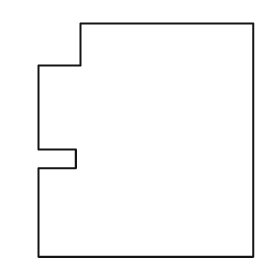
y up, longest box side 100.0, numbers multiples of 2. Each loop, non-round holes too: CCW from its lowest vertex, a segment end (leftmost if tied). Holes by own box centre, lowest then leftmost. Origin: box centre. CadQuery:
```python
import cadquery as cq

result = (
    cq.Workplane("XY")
    .moveTo(-46.0, -50.0)
    .lineTo(46.0, -50.0)
    .lineTo(46.0, 50.0)
    .lineTo(-28.0, 50.0)
    .lineTo(-28.0, 32.0)
    .lineTo(-46.0, 32.0)
    .lineTo(-46.0, -4.0)
    .lineTo(-30.0, -4.0)
    .lineTo(-30.0, -12.0)
    .lineTo(-46.0, -12.0)
    .close()
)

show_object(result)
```